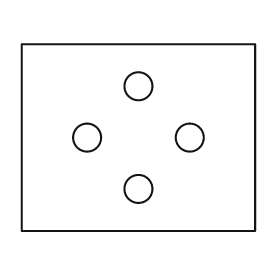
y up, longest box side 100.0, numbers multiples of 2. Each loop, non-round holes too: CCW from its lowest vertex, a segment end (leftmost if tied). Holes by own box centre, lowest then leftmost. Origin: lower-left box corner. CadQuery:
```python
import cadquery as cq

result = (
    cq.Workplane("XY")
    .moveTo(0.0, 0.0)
    .lineTo(100.0, 0.0)
    .lineTo(100.0, 80.0)
    .lineTo(0.0, 80.0)
    .close()
    .moveTo(50.0, 18.0)
    .circle(6.0)
    .moveTo(28.0, 40.0)
    .circle(6.0)
    .moveTo(72.0, 40.0)
    .circle(6.0)
    .moveTo(50.0, 62.0)
    .circle(6.0)
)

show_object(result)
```